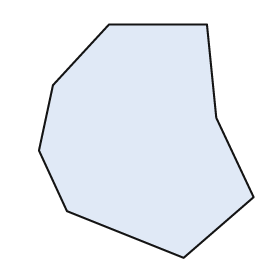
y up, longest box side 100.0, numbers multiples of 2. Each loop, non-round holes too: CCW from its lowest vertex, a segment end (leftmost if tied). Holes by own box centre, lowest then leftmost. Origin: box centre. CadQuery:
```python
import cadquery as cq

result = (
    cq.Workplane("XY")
    .moveTo(16.0, -50.0)
    .lineTo(46.0, -24.0)
    .lineTo(30.0, 10.0)
    .lineTo(26.0, 50.0)
    .lineTo(-16.0, 50.0)
    .lineTo(-40.0, 24.0)
    .lineTo(-46.0, -4.0)
    .lineTo(-34.0, -30.0)
    .close()
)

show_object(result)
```